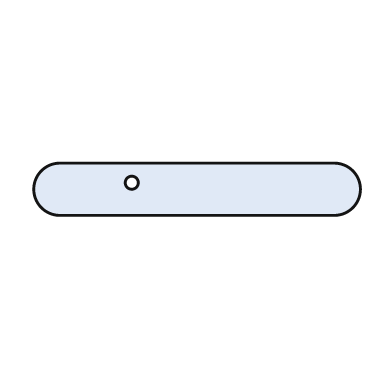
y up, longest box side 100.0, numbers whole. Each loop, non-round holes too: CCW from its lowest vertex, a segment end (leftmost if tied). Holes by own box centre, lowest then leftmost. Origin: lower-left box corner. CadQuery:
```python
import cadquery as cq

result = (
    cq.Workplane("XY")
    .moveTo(8.0, 0.0)
    .lineTo(92.0, 0.0)
    .threePointArc((100.0, 8.0), (92.0, 16.0))
    .lineTo(8.0, 16.0)
    .threePointArc((0.0, 8.0), (8.0, 0.0))
    .close()
    .moveTo(30.0, 10.0)
    .circle(2.0)
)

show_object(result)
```